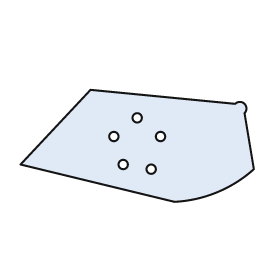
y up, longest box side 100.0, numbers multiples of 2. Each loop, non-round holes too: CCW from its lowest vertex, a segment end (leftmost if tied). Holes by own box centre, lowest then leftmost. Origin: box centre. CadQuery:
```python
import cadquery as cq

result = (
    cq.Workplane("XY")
    .moveTo(16.0, -24.0)
    .threePointArc((34.0, -20.0), (50.0, -10.0))
    .lineTo(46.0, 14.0)
    .threePointArc((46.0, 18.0), (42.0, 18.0))
    .lineTo(-20.0, 24.0)
    .lineTo(-50.0, -8.0)
    .close()
    .moveTo(6.0, -10.0)
    .circle(2.0)
    .moveTo(-6.0, -8.0)
    .circle(2.0)
    .moveTo(-10.0, 4.0)
    .circle(2.0)
    .moveTo(10.0, 4.0)
    .circle(2.0)
    .moveTo(0.0, 12.0)
    .circle(2.0)
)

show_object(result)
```